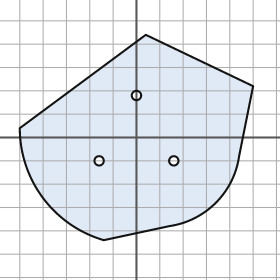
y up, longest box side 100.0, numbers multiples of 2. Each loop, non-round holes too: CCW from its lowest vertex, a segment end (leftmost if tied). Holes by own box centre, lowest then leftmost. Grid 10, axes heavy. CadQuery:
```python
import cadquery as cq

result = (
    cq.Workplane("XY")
    .moveTo(-14.0, -44.0)
    .lineTo(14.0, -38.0)
    .threePointArc((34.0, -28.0), (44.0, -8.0))
    .lineTo(50.0, 22.0)
    .lineTo(4.0, 44.0)
    .lineTo(-50.0, 4.0)
    .threePointArc((-40.0, -26.0), (-14.0, -44.0))
    .close()
    .moveTo(-16.0, -10.0)
    .circle(2.0)
    .moveTo(16.0, -10.0)
    .circle(2.0)
    .moveTo(0.0, 18.0)
    .circle(2.0)
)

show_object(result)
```